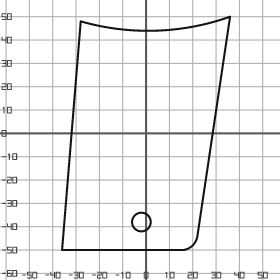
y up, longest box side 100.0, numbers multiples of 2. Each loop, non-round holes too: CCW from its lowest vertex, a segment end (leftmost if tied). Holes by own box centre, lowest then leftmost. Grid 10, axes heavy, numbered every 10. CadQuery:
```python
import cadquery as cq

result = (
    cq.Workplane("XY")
    .moveTo(-36.0, -50.0)
    .lineTo(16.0, -50.0)
    .threePointArc((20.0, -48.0), (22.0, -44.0))
    .lineTo(36.0, 50.0)
    .threePointArc((4.0, 44.0), (-28.0, 48.0))
    .close()
    .moveTo(-2.0, -38.0)
    .circle(4.0)
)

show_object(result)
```